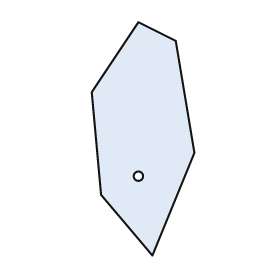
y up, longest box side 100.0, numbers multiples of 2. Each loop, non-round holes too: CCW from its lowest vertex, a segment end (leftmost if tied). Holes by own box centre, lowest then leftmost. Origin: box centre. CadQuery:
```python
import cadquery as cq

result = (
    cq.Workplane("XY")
    .moveTo(4.0, -50.0)
    .lineTo(22.0, -6.0)
    .lineTo(14.0, 42.0)
    .lineTo(-2.0, 50.0)
    .lineTo(-22.0, 20.0)
    .lineTo(-18.0, -24.0)
    .close()
    .moveTo(-2.0, -16.0)
    .circle(2.0)
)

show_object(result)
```